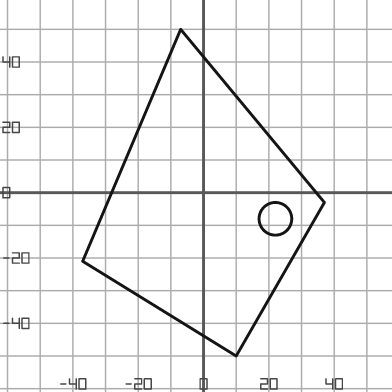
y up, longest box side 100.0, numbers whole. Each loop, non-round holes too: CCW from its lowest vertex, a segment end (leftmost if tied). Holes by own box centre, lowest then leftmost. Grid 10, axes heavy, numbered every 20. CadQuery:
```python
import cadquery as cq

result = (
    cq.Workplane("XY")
    .moveTo(10.0, -50.0)
    .lineTo(37.0, -3.0)
    .lineTo(-7.0, 50.0)
    .lineTo(-37.0, -21.0)
    .close()
    .moveTo(22.0, -8.0)
    .circle(5.0)
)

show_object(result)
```